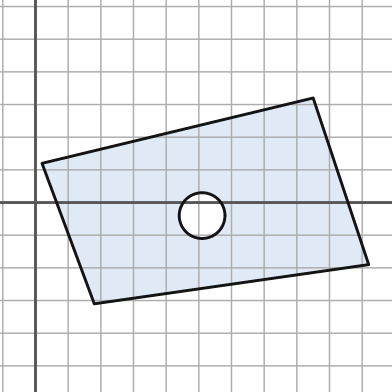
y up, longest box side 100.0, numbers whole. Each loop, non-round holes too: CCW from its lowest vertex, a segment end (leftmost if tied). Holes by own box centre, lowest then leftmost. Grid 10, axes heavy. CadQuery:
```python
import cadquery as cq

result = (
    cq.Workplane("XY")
    .moveTo(18.0, -31.0)
    .lineTo(102.0, -19.0)
    .lineTo(85.0, 32.0)
    .lineTo(2.0, 12.0)
    .close()
    .moveTo(51.0, -4.0)
    .circle(7.0)
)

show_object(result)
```